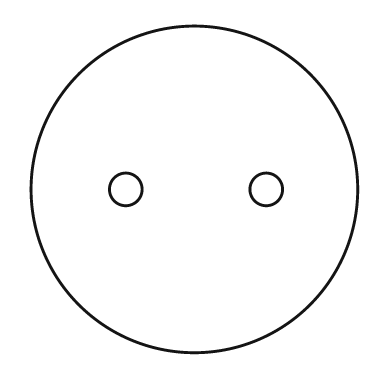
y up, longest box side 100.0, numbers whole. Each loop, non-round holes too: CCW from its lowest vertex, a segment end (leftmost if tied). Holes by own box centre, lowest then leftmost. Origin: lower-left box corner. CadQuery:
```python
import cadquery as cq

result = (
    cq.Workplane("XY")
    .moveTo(50.0, 50.0)
    .circle(50.0)
    .moveTo(29.0, 50.0)
    .circle(5.0)
    .moveTo(72.0, 50.0)
    .circle(5.0)
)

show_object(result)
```